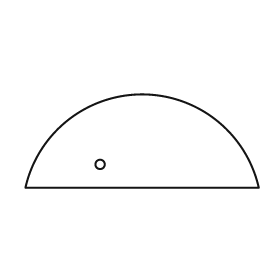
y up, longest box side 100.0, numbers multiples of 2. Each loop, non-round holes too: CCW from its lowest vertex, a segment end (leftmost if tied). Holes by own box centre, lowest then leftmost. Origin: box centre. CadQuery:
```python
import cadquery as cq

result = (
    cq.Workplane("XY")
    .moveTo(-50.0, -20.0)
    .lineTo(50.0, -20.0)
    .threePointArc((0.0, 20.0), (-50.0, -20.0))
    .close()
    .moveTo(-18.0, -10.0)
    .circle(2.0)
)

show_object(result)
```